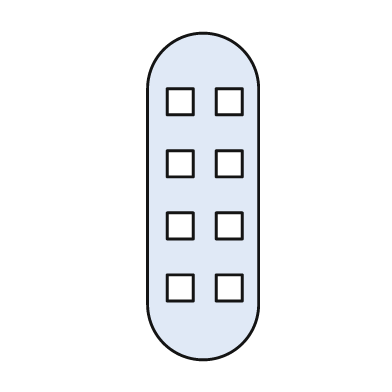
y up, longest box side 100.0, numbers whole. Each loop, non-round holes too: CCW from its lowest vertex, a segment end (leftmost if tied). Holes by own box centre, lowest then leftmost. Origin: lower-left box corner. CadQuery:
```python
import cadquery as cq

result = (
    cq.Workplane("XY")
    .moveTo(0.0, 17.0)
    .threePointArc((17.0, 0.0), (34.0, 17.0))
    .lineTo(34.0, 83.0)
    .threePointArc((17.0, 100.0), (0.0, 83.0))
    .close()
    .moveTo(6.0, 18.0)
    .lineTo(14.0, 18.0)
    .lineTo(14.0, 26.0)
    .lineTo(6.0, 26.0)
    .close()
    .moveTo(21.0, 18.0)
    .lineTo(29.0, 18.0)
    .lineTo(29.0, 26.0)
    .lineTo(21.0, 26.0)
    .close()
    .moveTo(6.0, 37.0)
    .lineTo(14.0, 37.0)
    .lineTo(14.0, 45.0)
    .lineTo(6.0, 45.0)
    .close()
    .moveTo(21.0, 37.0)
    .lineTo(29.0, 37.0)
    .lineTo(29.0, 45.0)
    .lineTo(21.0, 45.0)
    .close()
    .moveTo(6.0, 56.0)
    .lineTo(14.0, 56.0)
    .lineTo(14.0, 64.0)
    .lineTo(6.0, 64.0)
    .close()
    .moveTo(21.0, 56.0)
    .lineTo(29.0, 56.0)
    .lineTo(29.0, 64.0)
    .lineTo(21.0, 64.0)
    .close()
    .moveTo(6.0, 75.0)
    .lineTo(14.0, 75.0)
    .lineTo(14.0, 83.0)
    .lineTo(6.0, 83.0)
    .close()
    .moveTo(21.0, 75.0)
    .lineTo(29.0, 75.0)
    .lineTo(29.0, 83.0)
    .lineTo(21.0, 83.0)
    .close()
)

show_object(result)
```